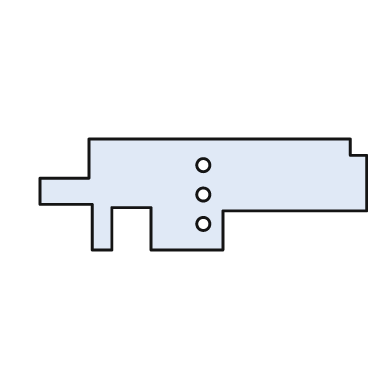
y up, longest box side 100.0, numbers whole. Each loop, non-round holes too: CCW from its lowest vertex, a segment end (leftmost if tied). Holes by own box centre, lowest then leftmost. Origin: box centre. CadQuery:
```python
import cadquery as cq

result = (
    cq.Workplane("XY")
    .moveTo(-34.0, -17.0)
    .lineTo(-28.0, -17.0)
    .lineTo(-28.0, -4.0)
    .lineTo(-16.0, -4.0)
    .lineTo(-16.0, -17.0)
    .lineTo(6.0, -17.0)
    .lineTo(6.0, -5.0)
    .lineTo(50.0, -5.0)
    .lineTo(50.0, 12.0)
    .lineTo(45.0, 12.0)
    .lineTo(45.0, 17.0)
    .lineTo(-35.0, 17.0)
    .lineTo(-35.0, 5.0)
    .lineTo(-50.0, 5.0)
    .lineTo(-50.0, -3.0)
    .lineTo(-34.0, -3.0)
    .close()
    .moveTo(0.0, -9.0)
    .circle(2.0)
    .moveTo(0.0, 0.0)
    .circle(2.0)
    .moveTo(0.0, 9.0)
    .circle(2.0)
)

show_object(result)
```